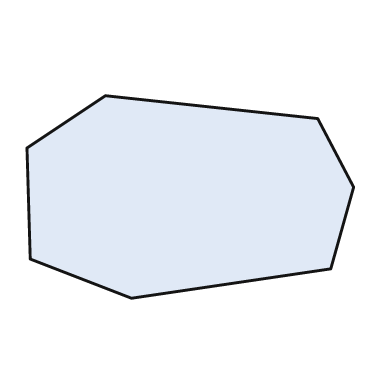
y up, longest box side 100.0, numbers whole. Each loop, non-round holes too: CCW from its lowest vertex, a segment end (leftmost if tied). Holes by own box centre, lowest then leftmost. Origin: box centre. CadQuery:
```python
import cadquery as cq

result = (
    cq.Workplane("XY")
    .moveTo(-18.0, -31.0)
    .lineTo(43.0, -22.0)
    .lineTo(50.0, 3.0)
    .lineTo(39.0, 24.0)
    .lineTo(-26.0, 31.0)
    .lineTo(-50.0, 15.0)
    .lineTo(-49.0, -19.0)
    .close()
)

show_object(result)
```